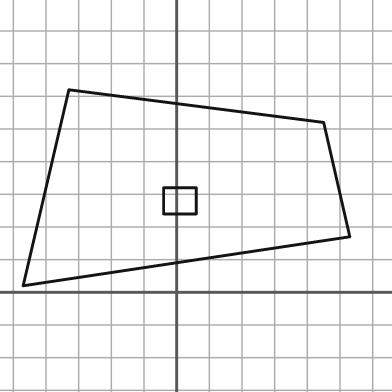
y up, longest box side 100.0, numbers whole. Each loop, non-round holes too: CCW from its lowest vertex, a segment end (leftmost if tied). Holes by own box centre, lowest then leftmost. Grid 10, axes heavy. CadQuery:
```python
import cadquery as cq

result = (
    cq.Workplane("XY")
    .moveTo(-47.0, 2.0)
    .lineTo(53.0, 17.0)
    .lineTo(45.0, 52.0)
    .lineTo(-33.0, 62.0)
    .close()
    .moveTo(-4.0, 24.0)
    .lineTo(6.0, 24.0)
    .lineTo(6.0, 32.0)
    .lineTo(-4.0, 32.0)
    .close()
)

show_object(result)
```